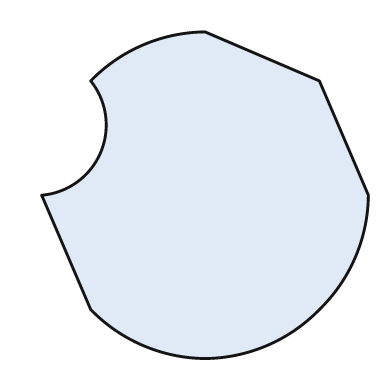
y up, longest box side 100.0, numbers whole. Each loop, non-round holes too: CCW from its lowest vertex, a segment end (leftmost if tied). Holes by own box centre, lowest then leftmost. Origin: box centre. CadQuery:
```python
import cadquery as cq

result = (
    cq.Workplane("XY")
    .moveTo(0.0, -50.0)
    .threePointArc((19.0, -46.0), (35.0, -35.0))
    .threePointArc((46.0, -19.0), (50.0, 0.0))
    .lineTo(35.0, 35.0)
    .lineTo(0.0, 50.0)
    .threePointArc((-19.0, 46.0), (-35.0, 35.0))
    .threePointArc((-32.0, 13.0), (-50.0, 0.0))
    .lineTo(-35.0, -35.0)
    .threePointArc((-19.0, -46.0), (0.0, -50.0))
    .close()
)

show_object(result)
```